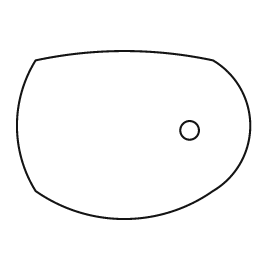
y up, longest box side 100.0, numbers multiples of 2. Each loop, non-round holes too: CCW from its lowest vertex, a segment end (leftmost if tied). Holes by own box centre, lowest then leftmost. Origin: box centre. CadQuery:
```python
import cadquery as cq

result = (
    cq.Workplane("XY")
    .moveTo(-42.0, -24.0)
    .threePointArc((-4.0, -36.0), (34.0, -24.0))
    .threePointArc((50.0, 4.0), (34.0, 32.0))
    .threePointArc((-4.0, 36.0), (-42.0, 32.0))
    .threePointArc((-50.0, 4.0), (-42.0, -24.0))
    .close()
    .moveTo(24.0, 2.0)
    .circle(4.0)
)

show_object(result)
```